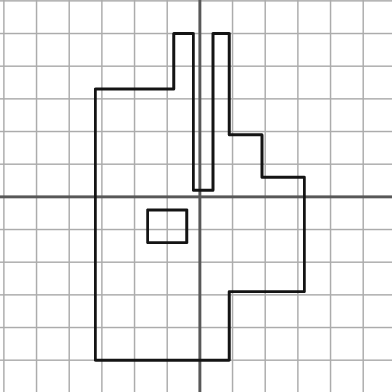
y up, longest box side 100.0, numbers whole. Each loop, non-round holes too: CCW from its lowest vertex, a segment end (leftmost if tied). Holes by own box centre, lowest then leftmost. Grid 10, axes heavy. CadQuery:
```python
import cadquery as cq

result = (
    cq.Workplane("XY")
    .moveTo(-32.0, -50.0)
    .lineTo(9.0, -50.0)
    .lineTo(9.0, -29.0)
    .lineTo(32.0, -29.0)
    .lineTo(32.0, 6.0)
    .lineTo(19.0, 6.0)
    .lineTo(19.0, 19.0)
    .lineTo(9.0, 19.0)
    .lineTo(9.0, 50.0)
    .lineTo(4.0, 50.0)
    .lineTo(4.0, 2.0)
    .lineTo(-2.0, 2.0)
    .lineTo(-2.0, 50.0)
    .lineTo(-8.0, 50.0)
    .lineTo(-8.0, 33.0)
    .lineTo(-32.0, 33.0)
    .close()
    .moveTo(-16.0, -14.0)
    .lineTo(-4.0, -14.0)
    .lineTo(-4.0, -4.0)
    .lineTo(-16.0, -4.0)
    .close()
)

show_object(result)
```